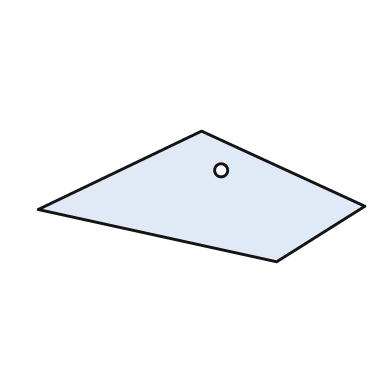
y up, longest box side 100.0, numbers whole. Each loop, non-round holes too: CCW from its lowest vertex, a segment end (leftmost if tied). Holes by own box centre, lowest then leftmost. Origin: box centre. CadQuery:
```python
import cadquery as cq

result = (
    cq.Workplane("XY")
    .moveTo(23.0, -20.0)
    .lineTo(50.0, -3.0)
    .lineTo(0.0, 20.0)
    .lineTo(-50.0, -4.0)
    .close()
    .moveTo(6.0, 8.0)
    .circle(2.0)
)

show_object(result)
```